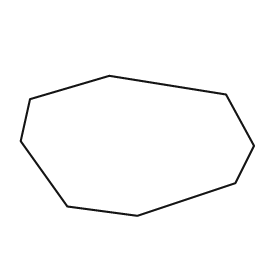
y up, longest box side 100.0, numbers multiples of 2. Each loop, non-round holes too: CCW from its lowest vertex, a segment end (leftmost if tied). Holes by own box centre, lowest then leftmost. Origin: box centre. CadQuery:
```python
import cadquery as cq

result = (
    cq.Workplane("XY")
    .moveTo(0.0, -30.0)
    .lineTo(42.0, -16.0)
    .lineTo(50.0, 0.0)
    .lineTo(38.0, 22.0)
    .lineTo(-12.0, 30.0)
    .lineTo(-46.0, 20.0)
    .lineTo(-50.0, 2.0)
    .lineTo(-30.0, -26.0)
    .close()
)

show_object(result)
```